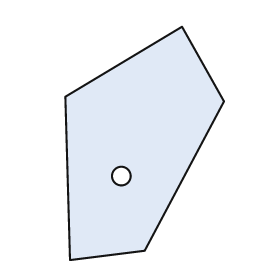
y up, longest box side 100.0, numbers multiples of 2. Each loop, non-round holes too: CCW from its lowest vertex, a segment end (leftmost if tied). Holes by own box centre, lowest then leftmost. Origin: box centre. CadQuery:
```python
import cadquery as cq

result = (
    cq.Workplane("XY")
    .moveTo(-32.0, -50.0)
    .lineTo(0.0, -46.0)
    .lineTo(34.0, 18.0)
    .lineTo(16.0, 50.0)
    .lineTo(-34.0, 20.0)
    .close()
    .moveTo(-10.0, -14.0)
    .circle(4.0)
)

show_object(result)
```